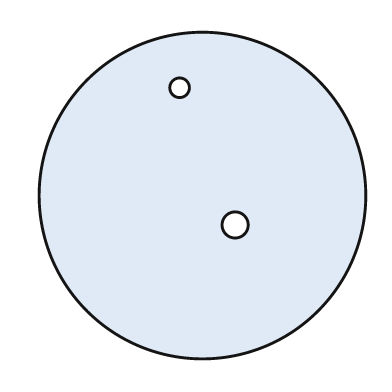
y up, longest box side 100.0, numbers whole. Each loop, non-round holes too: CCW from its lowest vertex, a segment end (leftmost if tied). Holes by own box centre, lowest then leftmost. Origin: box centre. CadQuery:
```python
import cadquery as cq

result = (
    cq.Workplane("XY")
    .moveTo(0.0, 0.0)
    .circle(50.0)
    .moveTo(10.0, -9.0)
    .circle(4.0)
    .moveTo(-7.0, 33.0)
    .circle(3.0)
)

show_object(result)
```